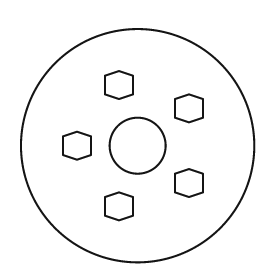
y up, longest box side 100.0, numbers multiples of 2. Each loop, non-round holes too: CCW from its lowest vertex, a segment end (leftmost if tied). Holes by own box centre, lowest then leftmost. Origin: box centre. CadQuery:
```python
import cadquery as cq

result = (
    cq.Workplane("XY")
    .moveTo(0.0, 0.0)
    .circle(50.0)
    .moveTo(-8.0, -32.0)
    .lineTo(-2.0, -30.0)
    .lineTo(-2.0, -22.0)
    .lineTo(-8.0, -20.0)
    .lineTo(-14.0, -22.0)
    .lineTo(-14.0, -30.0)
    .close()
    .moveTo(22.0, -22.0)
    .lineTo(28.0, -20.0)
    .lineTo(28.0, -12.0)
    .lineTo(22.0, -10.0)
    .lineTo(16.0, -12.0)
    .lineTo(16.0, -20.0)
    .close()
    .moveTo(-26.0, -6.0)
    .lineTo(-20.0, -4.0)
    .lineTo(-20.0, 4.0)
    .lineTo(-26.0, 6.0)
    .lineTo(-32.0, 4.0)
    .lineTo(-32.0, -4.0)
    .close()
    .moveTo(0.0, 0.0)
    .circle(12.0)
    .moveTo(22.0, 10.0)
    .lineTo(28.0, 12.0)
    .lineTo(28.0, 20.0)
    .lineTo(22.0, 22.0)
    .lineTo(16.0, 20.0)
    .lineTo(16.0, 12.0)
    .close()
    .moveTo(-8.0, 20.0)
    .lineTo(-2.0, 22.0)
    .lineTo(-2.0, 30.0)
    .lineTo(-8.0, 32.0)
    .lineTo(-14.0, 30.0)
    .lineTo(-14.0, 22.0)
    .close()
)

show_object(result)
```